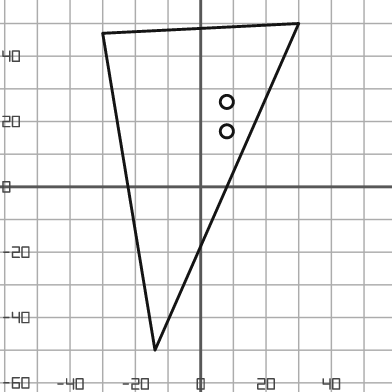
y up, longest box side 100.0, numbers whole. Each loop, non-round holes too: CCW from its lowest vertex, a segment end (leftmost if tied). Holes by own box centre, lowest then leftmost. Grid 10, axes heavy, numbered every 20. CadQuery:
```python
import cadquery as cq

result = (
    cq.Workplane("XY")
    .moveTo(-14.0, -50.0)
    .lineTo(30.0, 50.0)
    .lineTo(-30.0, 47.0)
    .close()
    .moveTo(8.0, 17.0)
    .circle(2.0)
    .moveTo(8.0, 26.0)
    .circle(2.0)
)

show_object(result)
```